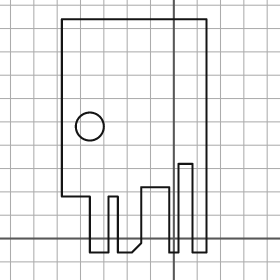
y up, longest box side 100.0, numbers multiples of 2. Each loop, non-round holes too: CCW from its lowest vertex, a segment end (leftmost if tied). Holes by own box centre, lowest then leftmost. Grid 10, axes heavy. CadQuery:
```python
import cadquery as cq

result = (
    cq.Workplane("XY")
    .moveTo(-36.0, -6.0)
    .lineTo(-28.0, -6.0)
    .lineTo(-28.0, 18.0)
    .lineTo(-24.0, 18.0)
    .lineTo(-24.0, -6.0)
    .lineTo(-18.0, -6.0)
    .lineTo(-14.0, -2.0)
    .lineTo(-14.0, 22.0)
    .lineTo(-2.0, 22.0)
    .lineTo(-2.0, -6.0)
    .lineTo(2.0, -6.0)
    .lineTo(2.0, 32.0)
    .lineTo(8.0, 32.0)
    .lineTo(8.0, -6.0)
    .lineTo(14.0, -6.0)
    .lineTo(14.0, 94.0)
    .lineTo(-48.0, 94.0)
    .lineTo(-48.0, 18.0)
    .lineTo(-36.0, 18.0)
    .close()
    .moveTo(-36.0, 48.0)
    .circle(6.0)
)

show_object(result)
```